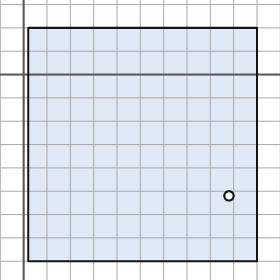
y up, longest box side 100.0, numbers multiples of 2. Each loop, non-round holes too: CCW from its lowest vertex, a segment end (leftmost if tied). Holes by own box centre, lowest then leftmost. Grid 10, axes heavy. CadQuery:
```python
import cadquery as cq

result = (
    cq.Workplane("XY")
    .moveTo(2.0, -80.0)
    .lineTo(100.0, -80.0)
    .lineTo(100.0, 20.0)
    .lineTo(2.0, 20.0)
    .close()
    .moveTo(88.0, -52.0)
    .circle(2.0)
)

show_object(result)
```